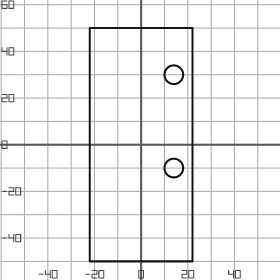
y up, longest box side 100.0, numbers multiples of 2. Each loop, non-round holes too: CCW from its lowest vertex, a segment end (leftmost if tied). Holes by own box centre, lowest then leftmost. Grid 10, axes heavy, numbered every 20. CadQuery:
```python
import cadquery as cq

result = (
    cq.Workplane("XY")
    .moveTo(-22.0, -50.0)
    .lineTo(22.0, -50.0)
    .lineTo(22.0, 50.0)
    .lineTo(-22.0, 50.0)
    .close()
    .moveTo(14.0, -10.0)
    .circle(4.0)
    .moveTo(14.0, 30.0)
    .circle(4.0)
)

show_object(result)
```